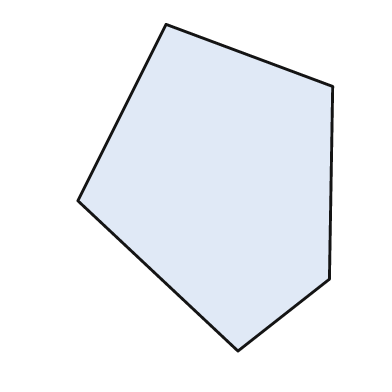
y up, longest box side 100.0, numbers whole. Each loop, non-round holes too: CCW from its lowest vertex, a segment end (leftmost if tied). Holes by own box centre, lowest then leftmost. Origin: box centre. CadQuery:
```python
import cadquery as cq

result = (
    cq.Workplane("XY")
    .moveTo(10.0, -50.0)
    .lineTo(38.0, -28.0)
    .lineTo(39.0, 31.0)
    .lineTo(-12.0, 50.0)
    .lineTo(-39.0, -4.0)
    .close()
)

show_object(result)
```